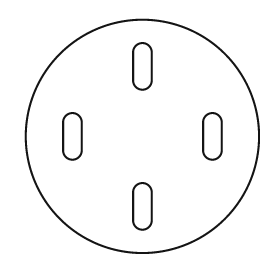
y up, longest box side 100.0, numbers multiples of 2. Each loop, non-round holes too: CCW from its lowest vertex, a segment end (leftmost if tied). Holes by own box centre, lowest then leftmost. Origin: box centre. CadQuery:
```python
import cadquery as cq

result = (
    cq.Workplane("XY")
    .moveTo(0.0, 0.0)
    .circle(50.0)
    .moveTo(-4.0, -36.0)
    .threePointArc((0.0, -40.0), (4.0, -36.0))
    .lineTo(4.0, -24.0)
    .threePointArc((0.0, -20.0), (-4.0, -24.0))
    .close()
    .moveTo(-34.0, -6.0)
    .threePointArc((-30.0, -10.0), (-26.0, -6.0))
    .lineTo(-26.0, 6.0)
    .threePointArc((-30.0, 10.0), (-34.0, 6.0))
    .close()
    .moveTo(26.0, -6.0)
    .threePointArc((30.0, -10.0), (34.0, -6.0))
    .lineTo(34.0, 6.0)
    .threePointArc((30.0, 10.0), (26.0, 6.0))
    .close()
    .moveTo(-4.0, 24.0)
    .threePointArc((0.0, 20.0), (4.0, 24.0))
    .lineTo(4.0, 36.0)
    .threePointArc((0.0, 40.0), (-4.0, 36.0))
    .close()
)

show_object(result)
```